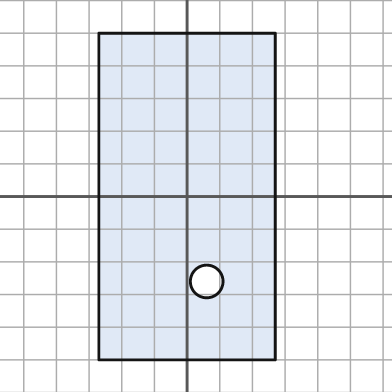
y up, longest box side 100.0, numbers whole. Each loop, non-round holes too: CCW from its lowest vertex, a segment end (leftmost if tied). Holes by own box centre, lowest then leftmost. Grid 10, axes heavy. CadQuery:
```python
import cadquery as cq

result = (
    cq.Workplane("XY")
    .moveTo(-27.0, -50.0)
    .lineTo(27.0, -50.0)
    .lineTo(27.0, 50.0)
    .lineTo(-27.0, 50.0)
    .close()
    .moveTo(6.0, -26.0)
    .circle(5.0)
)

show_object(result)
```